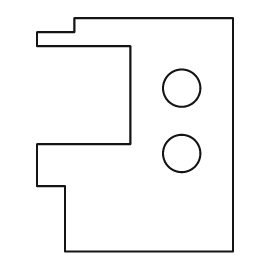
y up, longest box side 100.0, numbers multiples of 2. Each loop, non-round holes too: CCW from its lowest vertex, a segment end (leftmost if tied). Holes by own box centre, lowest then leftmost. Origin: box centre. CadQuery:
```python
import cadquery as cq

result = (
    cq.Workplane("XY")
    .moveTo(-30.0, -50.0)
    .lineTo(42.0, -50.0)
    .lineTo(42.0, 50.0)
    .lineTo(-26.0, 50.0)
    .lineTo(-26.0, 44.0)
    .lineTo(-42.0, 44.0)
    .lineTo(-42.0, 38.0)
    .lineTo(-2.0, 38.0)
    .lineTo(-2.0, -4.0)
    .lineTo(-42.0, -4.0)
    .lineTo(-42.0, -22.0)
    .lineTo(-30.0, -22.0)
    .close()
    .moveTo(20.0, -8.0)
    .circle(8.0)
    .moveTo(20.0, 20.0)
    .circle(8.0)
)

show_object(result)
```